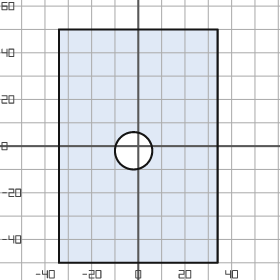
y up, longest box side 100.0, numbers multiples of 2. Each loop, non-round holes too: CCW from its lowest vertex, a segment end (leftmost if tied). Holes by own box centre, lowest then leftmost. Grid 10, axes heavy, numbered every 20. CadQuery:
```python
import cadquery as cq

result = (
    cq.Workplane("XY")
    .moveTo(-34.0, -50.0)
    .lineTo(34.0, -50.0)
    .lineTo(34.0, 50.0)
    .lineTo(-34.0, 50.0)
    .close()
    .moveTo(-2.0, -2.0)
    .circle(8.0)
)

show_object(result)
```